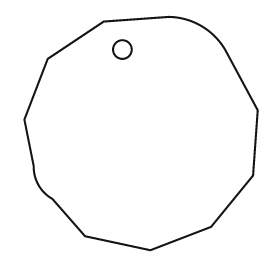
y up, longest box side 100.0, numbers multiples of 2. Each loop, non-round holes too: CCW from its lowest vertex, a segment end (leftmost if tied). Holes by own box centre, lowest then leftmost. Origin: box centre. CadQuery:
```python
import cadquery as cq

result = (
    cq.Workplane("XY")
    .moveTo(4.0, -50.0)
    .lineTo(30.0, -40.0)
    .lineTo(48.0, -18.0)
    .lineTo(50.0, 10.0)
    .lineTo(36.0, 36.0)
    .threePointArc((26.0, 46.0), (12.0, 50.0))
    .lineTo(-16.0, 48.0)
    .lineTo(-40.0, 32.0)
    .lineTo(-50.0, 6.0)
    .lineTo(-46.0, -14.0)
    .threePointArc((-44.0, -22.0), (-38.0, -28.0))
    .lineTo(-24.0, -44.0)
    .close()
    .moveTo(-8.0, 36.0)
    .circle(4.0)
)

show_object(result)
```